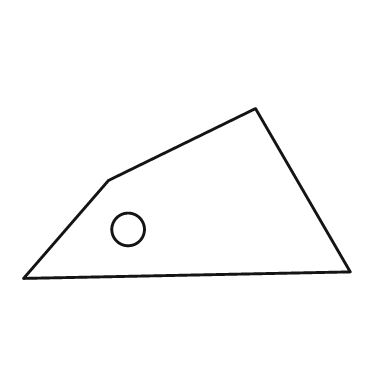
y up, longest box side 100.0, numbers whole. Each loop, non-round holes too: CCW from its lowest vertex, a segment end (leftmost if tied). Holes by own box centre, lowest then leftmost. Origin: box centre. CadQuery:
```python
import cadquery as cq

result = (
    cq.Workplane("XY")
    .moveTo(-50.0, -26.0)
    .lineTo(50.0, -24.0)
    .lineTo(21.0, 26.0)
    .lineTo(-24.0, 4.0)
    .close()
    .moveTo(-18.0, -11.0)
    .circle(5.0)
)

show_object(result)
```